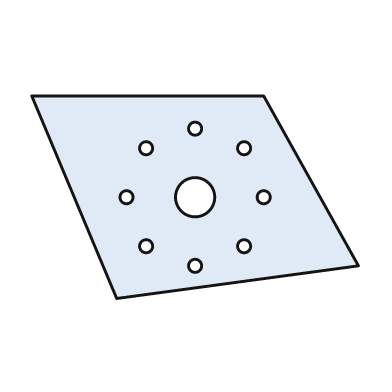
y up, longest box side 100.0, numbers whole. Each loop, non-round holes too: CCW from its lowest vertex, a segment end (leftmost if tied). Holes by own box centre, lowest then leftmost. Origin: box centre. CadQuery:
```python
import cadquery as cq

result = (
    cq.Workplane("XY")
    .moveTo(-24.0, -31.0)
    .lineTo(50.0, -21.0)
    .lineTo(21.0, 31.0)
    .lineTo(-50.0, 31.0)
    .close()
    .moveTo(0.0, -21.0)
    .circle(2.0)
    .moveTo(-15.0, -15.0)
    .circle(2.0)
    .moveTo(15.0, -15.0)
    .circle(2.0)
    .moveTo(-21.0, 0.0)
    .circle(2.0)
    .moveTo(0.0, 0.0)
    .circle(6.0)
    .moveTo(21.0, 0.0)
    .circle(2.0)
    .moveTo(-15.0, 15.0)
    .circle(2.0)
    .moveTo(15.0, 15.0)
    .circle(2.0)
    .moveTo(0.0, 21.0)
    .circle(2.0)
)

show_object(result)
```